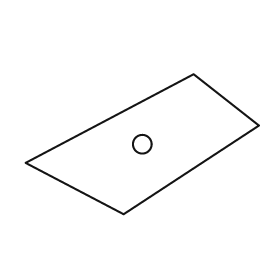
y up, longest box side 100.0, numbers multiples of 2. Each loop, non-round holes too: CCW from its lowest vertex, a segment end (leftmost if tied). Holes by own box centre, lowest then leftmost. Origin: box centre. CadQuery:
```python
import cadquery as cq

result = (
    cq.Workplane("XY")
    .moveTo(-8.0, -30.0)
    .lineTo(50.0, 8.0)
    .lineTo(22.0, 30.0)
    .lineTo(-50.0, -8.0)
    .close()
    .moveTo(0.0, 0.0)
    .circle(4.0)
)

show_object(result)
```